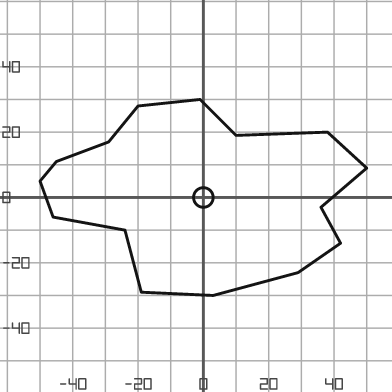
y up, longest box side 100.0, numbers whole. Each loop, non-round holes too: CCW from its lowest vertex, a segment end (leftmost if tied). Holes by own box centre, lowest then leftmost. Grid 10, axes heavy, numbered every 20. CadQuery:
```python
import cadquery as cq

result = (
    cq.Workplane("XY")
    .moveTo(3.0, -30.0)
    .lineTo(29.0, -23.0)
    .lineTo(42.0, -14.0)
    .lineTo(36.0, -3.0)
    .lineTo(50.0, 9.0)
    .lineTo(38.0, 20.0)
    .lineTo(10.0, 19.0)
    .lineTo(-1.0, 30.0)
    .lineTo(-20.0, 28.0)
    .lineTo(-29.0, 17.0)
    .lineTo(-45.0, 11.0)
    .lineTo(-50.0, 5.0)
    .lineTo(-46.0, -6.0)
    .lineTo(-24.0, -10.0)
    .lineTo(-19.0, -29.0)
    .close()
    .moveTo(0.0, 0.0)
    .circle(3.0)
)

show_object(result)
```